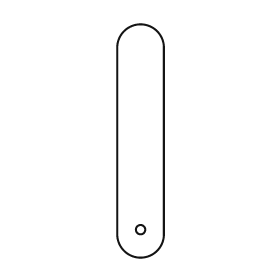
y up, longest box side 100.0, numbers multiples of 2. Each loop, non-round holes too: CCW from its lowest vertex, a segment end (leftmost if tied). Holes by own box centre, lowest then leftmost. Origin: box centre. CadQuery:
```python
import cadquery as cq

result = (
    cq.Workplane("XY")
    .moveTo(-10.0, -40.0)
    .threePointArc((0.0, -50.0), (10.0, -40.0))
    .lineTo(10.0, 40.0)
    .threePointArc((0.0, 50.0), (-10.0, 40.0))
    .close()
    .moveTo(0.0, -38.0)
    .circle(2.0)
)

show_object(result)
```